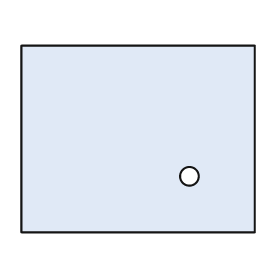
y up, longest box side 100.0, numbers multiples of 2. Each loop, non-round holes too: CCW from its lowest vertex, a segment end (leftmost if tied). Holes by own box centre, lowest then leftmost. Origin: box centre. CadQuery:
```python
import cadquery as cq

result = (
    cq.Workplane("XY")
    .moveTo(-50.0, -40.0)
    .lineTo(50.0, -40.0)
    .lineTo(50.0, 40.0)
    .lineTo(-50.0, 40.0)
    .close()
    .moveTo(22.0, -16.0)
    .circle(4.0)
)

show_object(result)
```